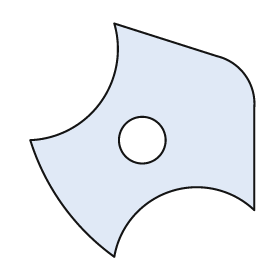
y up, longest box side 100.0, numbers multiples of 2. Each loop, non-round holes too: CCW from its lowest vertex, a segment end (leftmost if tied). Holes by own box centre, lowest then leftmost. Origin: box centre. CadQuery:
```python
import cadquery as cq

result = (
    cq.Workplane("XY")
    .moveTo(-12.0, -50.0)
    .threePointArc((12.0, -22.0), (48.0, -30.0))
    .lineTo(48.0, 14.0)
    .threePointArc((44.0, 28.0), (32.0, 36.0))
    .lineTo(-12.0, 50.0)
    .threePointArc((-18.0, 16.0), (-48.0, 0.0))
    .threePointArc((-34.0, -28.0), (-12.0, -50.0))
    .close()
    .moveTo(0.0, 0.0)
    .circle(10.0)
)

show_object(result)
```